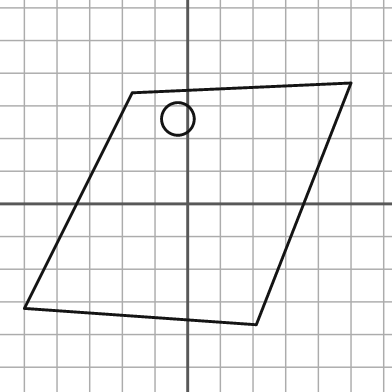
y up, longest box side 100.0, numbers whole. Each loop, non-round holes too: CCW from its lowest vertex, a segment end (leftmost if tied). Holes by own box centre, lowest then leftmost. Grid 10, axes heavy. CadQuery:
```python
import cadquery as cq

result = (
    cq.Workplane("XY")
    .moveTo(21.0, -37.0)
    .lineTo(50.0, 37.0)
    .lineTo(-17.0, 34.0)
    .lineTo(-50.0, -32.0)
    .close()
    .moveTo(-3.0, 26.0)
    .circle(5.0)
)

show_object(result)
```